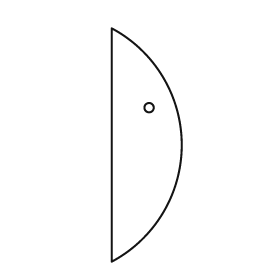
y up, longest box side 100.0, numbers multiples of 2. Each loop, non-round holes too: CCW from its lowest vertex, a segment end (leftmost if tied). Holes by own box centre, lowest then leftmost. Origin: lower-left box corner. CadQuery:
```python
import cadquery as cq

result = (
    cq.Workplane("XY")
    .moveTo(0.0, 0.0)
    .threePointArc((30.0, 50.0), (0.0, 100.0))
    .close()
    .moveTo(16.0, 66.0)
    .circle(2.0)
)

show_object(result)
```